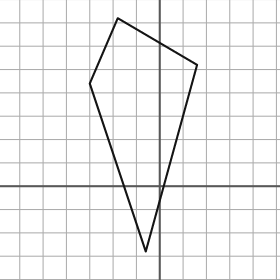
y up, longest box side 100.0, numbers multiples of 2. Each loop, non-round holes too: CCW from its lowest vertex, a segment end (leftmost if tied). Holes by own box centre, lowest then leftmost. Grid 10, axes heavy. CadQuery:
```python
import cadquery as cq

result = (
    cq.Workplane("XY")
    .moveTo(-6.0, -28.0)
    .lineTo(16.0, 52.0)
    .lineTo(-18.0, 72.0)
    .lineTo(-30.0, 44.0)
    .close()
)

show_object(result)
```